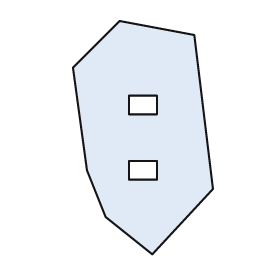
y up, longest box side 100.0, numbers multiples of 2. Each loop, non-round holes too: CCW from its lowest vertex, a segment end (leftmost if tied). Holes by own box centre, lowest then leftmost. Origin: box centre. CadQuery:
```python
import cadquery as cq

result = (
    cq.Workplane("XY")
    .moveTo(4.0, -50.0)
    .lineTo(30.0, -22.0)
    .lineTo(22.0, 44.0)
    .lineTo(-10.0, 50.0)
    .lineTo(-30.0, 30.0)
    .lineTo(-24.0, -14.0)
    .lineTo(-16.0, -34.0)
    .close()
    .moveTo(-6.0, -18.0)
    .lineTo(6.0, -18.0)
    .lineTo(6.0, -10.0)
    .lineTo(-6.0, -10.0)
    .close()
    .moveTo(-6.0, 10.0)
    .lineTo(6.0, 10.0)
    .lineTo(6.0, 18.0)
    .lineTo(-6.0, 18.0)
    .close()
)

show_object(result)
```